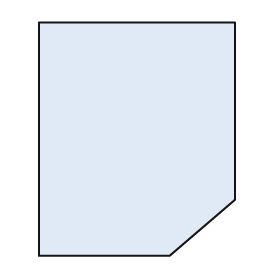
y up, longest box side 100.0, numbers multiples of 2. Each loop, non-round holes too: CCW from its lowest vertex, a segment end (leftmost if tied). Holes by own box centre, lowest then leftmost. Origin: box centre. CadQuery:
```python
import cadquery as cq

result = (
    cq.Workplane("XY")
    .moveTo(-42.0, -50.0)
    .lineTo(14.0, -50.0)
    .lineTo(42.0, -26.0)
    .lineTo(42.0, 50.0)
    .lineTo(-42.0, 50.0)
    .close()
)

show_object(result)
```